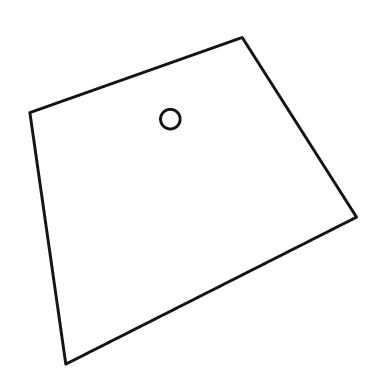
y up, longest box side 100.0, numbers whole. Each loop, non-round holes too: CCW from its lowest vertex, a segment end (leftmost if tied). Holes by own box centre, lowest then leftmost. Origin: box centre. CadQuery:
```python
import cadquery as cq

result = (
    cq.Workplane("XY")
    .moveTo(-39.0, -50.0)
    .lineTo(50.0, -5.0)
    .lineTo(15.0, 50.0)
    .lineTo(-50.0, 27.0)
    .close()
    .moveTo(-7.0, 25.0)
    .circle(3.0)
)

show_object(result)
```